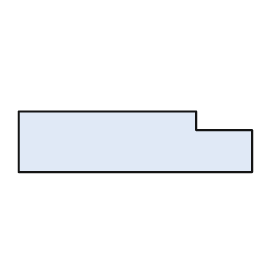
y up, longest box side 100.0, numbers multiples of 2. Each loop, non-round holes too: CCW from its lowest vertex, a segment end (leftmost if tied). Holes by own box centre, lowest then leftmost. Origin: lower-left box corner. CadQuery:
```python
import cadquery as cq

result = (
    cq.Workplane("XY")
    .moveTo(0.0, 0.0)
    .lineTo(100.0, 0.0)
    .lineTo(100.0, 18.0)
    .lineTo(76.0, 18.0)
    .lineTo(76.0, 26.0)
    .lineTo(0.0, 26.0)
    .close()
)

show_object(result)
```